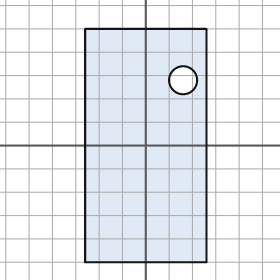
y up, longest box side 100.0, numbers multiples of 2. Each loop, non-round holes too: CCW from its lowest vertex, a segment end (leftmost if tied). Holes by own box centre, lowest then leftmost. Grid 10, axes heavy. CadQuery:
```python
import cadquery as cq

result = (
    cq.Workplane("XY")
    .moveTo(-26.0, -50.0)
    .lineTo(26.0, -50.0)
    .lineTo(26.0, 50.0)
    .lineTo(-26.0, 50.0)
    .close()
    .moveTo(16.0, 28.0)
    .circle(6.0)
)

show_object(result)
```